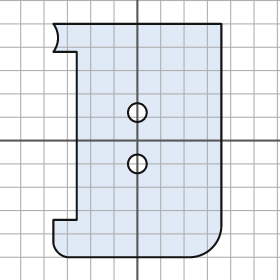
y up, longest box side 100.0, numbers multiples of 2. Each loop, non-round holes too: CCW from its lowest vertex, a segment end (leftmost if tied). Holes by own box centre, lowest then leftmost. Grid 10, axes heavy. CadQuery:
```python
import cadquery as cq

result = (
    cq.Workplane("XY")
    .moveTo(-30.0, -50.0)
    .lineTo(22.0, -50.0)
    .threePointArc((32.0, -46.0), (36.0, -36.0))
    .lineTo(36.0, 50.0)
    .lineTo(-36.0, 50.0)
    .threePointArc((-34.0, 44.0), (-36.0, 38.0))
    .lineTo(-26.0, 38.0)
    .lineTo(-26.0, -34.0)
    .lineTo(-36.0, -34.0)
    .lineTo(-36.0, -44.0)
    .threePointArc((-34.0, -48.0), (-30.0, -50.0))
    .close()
    .moveTo(0.0, -10.0)
    .circle(4.0)
    .moveTo(0.0, 12.0)
    .circle(4.0)
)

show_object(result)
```